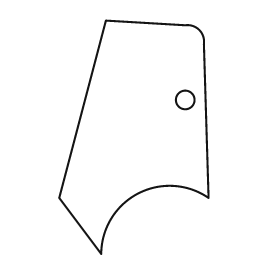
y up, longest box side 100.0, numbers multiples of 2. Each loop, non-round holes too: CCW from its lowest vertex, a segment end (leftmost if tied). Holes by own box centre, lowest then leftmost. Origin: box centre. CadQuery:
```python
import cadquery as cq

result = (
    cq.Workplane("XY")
    .moveTo(-14.0, -50.0)
    .threePointArc((2.0, -24.0), (32.0, -26.0))
    .lineTo(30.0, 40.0)
    .threePointArc((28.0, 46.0), (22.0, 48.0))
    .lineTo(-12.0, 50.0)
    .lineTo(-32.0, -26.0)
    .close()
    .moveTo(22.0, 16.0)
    .circle(4.0)
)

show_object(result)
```